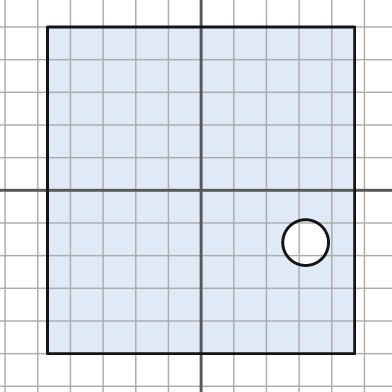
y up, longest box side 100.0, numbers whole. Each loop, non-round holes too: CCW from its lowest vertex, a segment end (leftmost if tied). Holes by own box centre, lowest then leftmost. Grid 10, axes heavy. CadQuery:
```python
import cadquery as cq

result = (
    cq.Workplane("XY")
    .moveTo(-47.0, -50.0)
    .lineTo(47.0, -50.0)
    .lineTo(47.0, 50.0)
    .lineTo(-47.0, 50.0)
    .close()
    .moveTo(32.0, -16.0)
    .circle(7.0)
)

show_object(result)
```